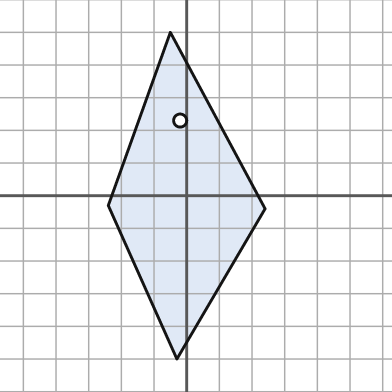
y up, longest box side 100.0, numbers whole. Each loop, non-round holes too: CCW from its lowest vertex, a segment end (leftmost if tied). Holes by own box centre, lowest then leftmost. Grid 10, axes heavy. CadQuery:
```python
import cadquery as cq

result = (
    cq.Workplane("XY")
    .moveTo(-3.0, -50.0)
    .lineTo(24.0, -4.0)
    .lineTo(-5.0, 50.0)
    .lineTo(-24.0, -3.0)
    .close()
    .moveTo(-2.0, 23.0)
    .circle(2.0)
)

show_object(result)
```